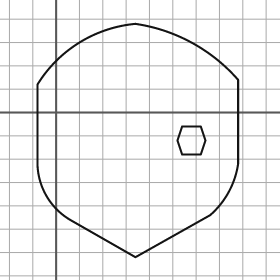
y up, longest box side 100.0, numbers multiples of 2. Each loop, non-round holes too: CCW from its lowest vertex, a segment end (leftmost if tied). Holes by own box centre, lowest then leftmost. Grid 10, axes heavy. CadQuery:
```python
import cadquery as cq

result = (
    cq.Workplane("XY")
    .moveTo(34.0, -62.0)
    .lineTo(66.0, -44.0)
    .threePointArc((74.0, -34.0), (78.0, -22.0))
    .lineTo(78.0, 14.0)
    .threePointArc((58.0, 30.0), (34.0, 38.0))
    .threePointArc((10.0, 30.0), (-8.0, 12.0))
    .lineTo(-8.0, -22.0)
    .threePointArc((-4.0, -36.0), (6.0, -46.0))
    .close()
    .moveTo(54.0, -18.0)
    .lineTo(62.0, -18.0)
    .lineTo(64.0, -12.0)
    .lineTo(62.0, -6.0)
    .lineTo(54.0, -6.0)
    .lineTo(52.0, -12.0)
    .close()
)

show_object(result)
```